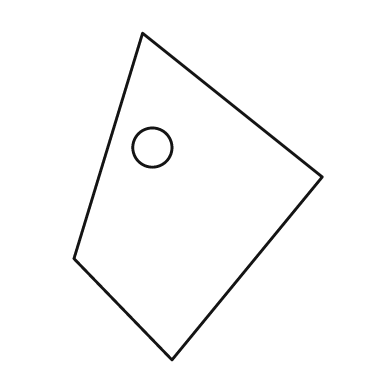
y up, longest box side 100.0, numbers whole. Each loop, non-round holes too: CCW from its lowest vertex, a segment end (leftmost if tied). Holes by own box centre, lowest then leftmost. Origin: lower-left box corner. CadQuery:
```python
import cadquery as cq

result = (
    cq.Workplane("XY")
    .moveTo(30.0, 0.0)
    .lineTo(76.0, 56.0)
    .lineTo(21.0, 100.0)
    .lineTo(0.0, 31.0)
    .close()
    .moveTo(24.0, 65.0)
    .circle(6.0)
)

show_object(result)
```